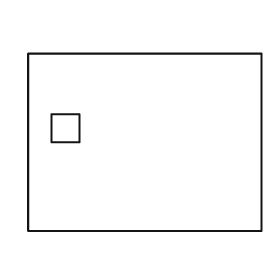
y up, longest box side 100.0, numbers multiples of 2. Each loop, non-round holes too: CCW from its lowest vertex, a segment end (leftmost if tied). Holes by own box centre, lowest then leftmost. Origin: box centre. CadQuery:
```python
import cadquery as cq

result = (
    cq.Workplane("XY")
    .moveTo(-50.0, -38.0)
    .lineTo(50.0, -38.0)
    .lineTo(50.0, 38.0)
    .lineTo(-50.0, 38.0)
    .close()
    .moveTo(-40.0, 0.0)
    .lineTo(-28.0, 0.0)
    .lineTo(-28.0, 12.0)
    .lineTo(-40.0, 12.0)
    .close()
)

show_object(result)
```